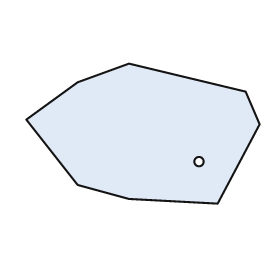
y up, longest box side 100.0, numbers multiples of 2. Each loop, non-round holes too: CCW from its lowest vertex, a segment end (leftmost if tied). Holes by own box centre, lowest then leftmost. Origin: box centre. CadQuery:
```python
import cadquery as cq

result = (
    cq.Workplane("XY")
    .moveTo(32.0, -30.0)
    .lineTo(50.0, 4.0)
    .lineTo(44.0, 18.0)
    .lineTo(-6.0, 30.0)
    .lineTo(-28.0, 22.0)
    .lineTo(-50.0, 6.0)
    .lineTo(-28.0, -22.0)
    .lineTo(-6.0, -28.0)
    .close()
    .moveTo(24.0, -12.0)
    .circle(2.0)
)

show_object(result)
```